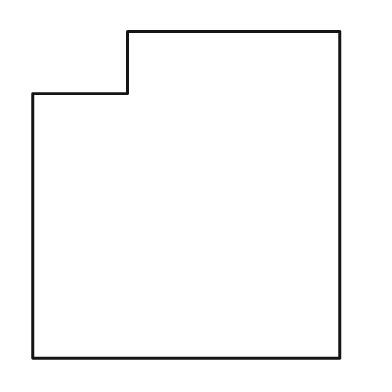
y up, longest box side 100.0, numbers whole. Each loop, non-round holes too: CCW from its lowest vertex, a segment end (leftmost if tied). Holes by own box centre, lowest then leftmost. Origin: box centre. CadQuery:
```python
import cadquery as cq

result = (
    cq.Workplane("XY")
    .moveTo(-47.0, -50.0)
    .lineTo(47.0, -50.0)
    .lineTo(47.0, 50.0)
    .lineTo(-18.0, 50.0)
    .lineTo(-18.0, 31.0)
    .lineTo(-47.0, 31.0)
    .close()
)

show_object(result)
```